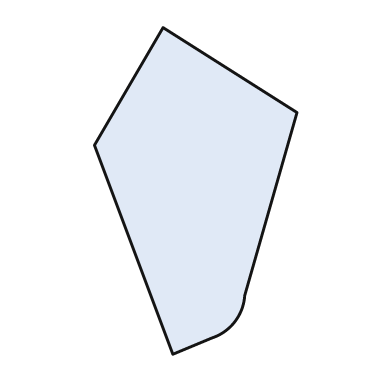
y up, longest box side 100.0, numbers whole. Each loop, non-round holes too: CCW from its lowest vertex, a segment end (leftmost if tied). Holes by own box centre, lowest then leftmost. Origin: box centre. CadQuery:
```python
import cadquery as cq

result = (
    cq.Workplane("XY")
    .moveTo(-7.0, -50.0)
    .lineTo(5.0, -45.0)
    .threePointArc((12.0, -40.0), (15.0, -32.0))
    .lineTo(31.0, 24.0)
    .lineTo(-10.0, 50.0)
    .lineTo(-31.0, 14.0)
    .close()
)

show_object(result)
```